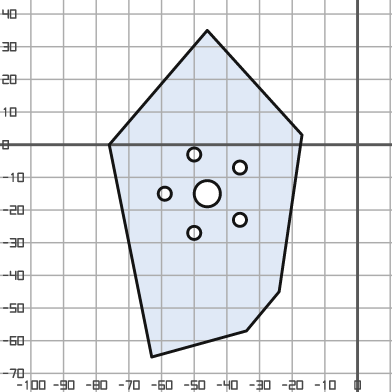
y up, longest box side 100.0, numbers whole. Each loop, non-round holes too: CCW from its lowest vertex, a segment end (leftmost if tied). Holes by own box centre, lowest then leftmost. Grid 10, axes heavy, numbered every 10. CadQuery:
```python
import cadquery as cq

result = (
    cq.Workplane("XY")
    .moveTo(-63.0, -65.0)
    .lineTo(-34.0, -57.0)
    .lineTo(-24.0, -45.0)
    .lineTo(-17.0, 3.0)
    .lineTo(-46.0, 35.0)
    .lineTo(-76.0, 0.0)
    .close()
    .moveTo(-50.0, -27.0)
    .circle(2.0)
    .moveTo(-36.0, -23.0)
    .circle(2.0)
    .moveTo(-59.0, -15.0)
    .circle(2.0)
    .moveTo(-46.0, -15.0)
    .circle(4.0)
    .moveTo(-36.0, -7.0)
    .circle(2.0)
    .moveTo(-50.0, -3.0)
    .circle(2.0)
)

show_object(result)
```